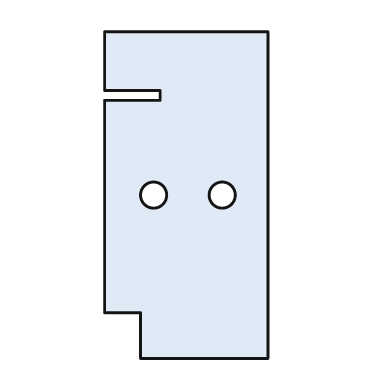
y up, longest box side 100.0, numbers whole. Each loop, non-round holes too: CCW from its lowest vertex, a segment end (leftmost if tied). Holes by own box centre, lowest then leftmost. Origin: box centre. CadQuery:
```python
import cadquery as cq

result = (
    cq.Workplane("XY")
    .moveTo(-14.0, -50.0)
    .lineTo(25.0, -50.0)
    .lineTo(25.0, 50.0)
    .lineTo(-25.0, 50.0)
    .lineTo(-25.0, 32.0)
    .lineTo(-8.0, 32.0)
    .lineTo(-8.0, 29.0)
    .lineTo(-25.0, 29.0)
    .lineTo(-25.0, -36.0)
    .lineTo(-14.0, -36.0)
    .close()
    .moveTo(-10.0, 0.0)
    .circle(4.0)
    .moveTo(11.0, 0.0)
    .circle(4.0)
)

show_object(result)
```